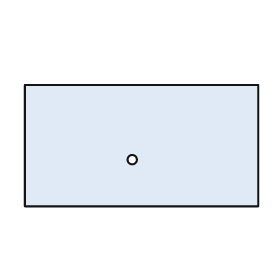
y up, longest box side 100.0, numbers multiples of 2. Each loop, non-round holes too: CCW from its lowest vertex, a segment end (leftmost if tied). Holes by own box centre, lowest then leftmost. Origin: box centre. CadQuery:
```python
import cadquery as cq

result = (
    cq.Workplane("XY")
    .moveTo(-50.0, -26.0)
    .lineTo(50.0, -26.0)
    .lineTo(50.0, 26.0)
    .lineTo(-50.0, 26.0)
    .close()
    .moveTo(-4.0, -6.0)
    .circle(2.0)
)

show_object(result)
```